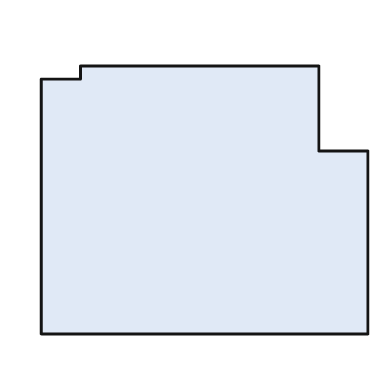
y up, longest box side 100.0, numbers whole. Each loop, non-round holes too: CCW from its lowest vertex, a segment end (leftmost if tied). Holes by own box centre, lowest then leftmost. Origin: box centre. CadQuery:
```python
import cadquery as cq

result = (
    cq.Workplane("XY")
    .moveTo(-50.0, -41.0)
    .lineTo(50.0, -41.0)
    .lineTo(50.0, 15.0)
    .lineTo(35.0, 15.0)
    .lineTo(35.0, 41.0)
    .lineTo(-38.0, 41.0)
    .lineTo(-38.0, 37.0)
    .lineTo(-50.0, 37.0)
    .close()
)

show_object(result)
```